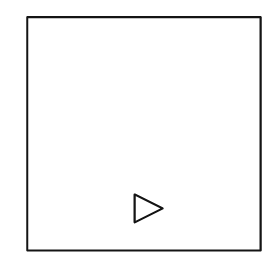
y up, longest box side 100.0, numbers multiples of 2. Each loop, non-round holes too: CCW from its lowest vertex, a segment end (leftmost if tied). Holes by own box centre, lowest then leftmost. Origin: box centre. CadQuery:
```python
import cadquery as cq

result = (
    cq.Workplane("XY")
    .moveTo(-50.0, -50.0)
    .lineTo(50.0, -50.0)
    .lineTo(50.0, 50.0)
    .lineTo(-50.0, 50.0)
    .close()
    .moveTo(-4.0, -38.0)
    .lineTo(8.0, -32.0)
    .lineTo(-4.0, -26.0)
    .close()
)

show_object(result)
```